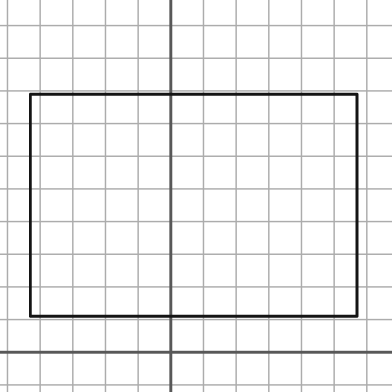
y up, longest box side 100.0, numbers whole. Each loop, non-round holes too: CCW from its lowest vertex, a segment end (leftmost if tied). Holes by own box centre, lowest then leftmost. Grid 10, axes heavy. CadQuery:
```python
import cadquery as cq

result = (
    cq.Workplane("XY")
    .moveTo(-43.0, 11.0)
    .lineTo(57.0, 11.0)
    .lineTo(57.0, 79.0)
    .lineTo(-43.0, 79.0)
    .close()
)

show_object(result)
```